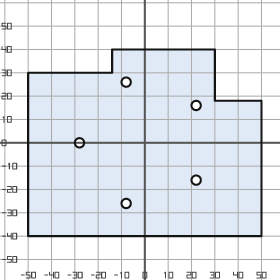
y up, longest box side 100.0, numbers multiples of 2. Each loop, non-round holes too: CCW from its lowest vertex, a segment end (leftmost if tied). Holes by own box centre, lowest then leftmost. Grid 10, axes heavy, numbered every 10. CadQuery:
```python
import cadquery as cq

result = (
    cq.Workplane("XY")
    .moveTo(-50.0, -40.0)
    .lineTo(50.0, -40.0)
    .lineTo(50.0, 18.0)
    .lineTo(30.0, 18.0)
    .lineTo(30.0, 40.0)
    .lineTo(-14.0, 40.0)
    .lineTo(-14.0, 30.0)
    .lineTo(-50.0, 30.0)
    .close()
    .moveTo(-8.0, -26.0)
    .circle(2.0)
    .moveTo(22.0, -16.0)
    .circle(2.0)
    .moveTo(-28.0, 0.0)
    .circle(2.0)
    .moveTo(22.0, 16.0)
    .circle(2.0)
    .moveTo(-8.0, 26.0)
    .circle(2.0)
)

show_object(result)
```